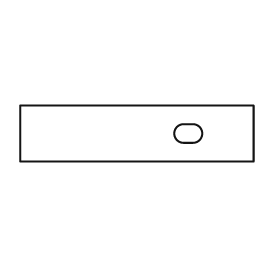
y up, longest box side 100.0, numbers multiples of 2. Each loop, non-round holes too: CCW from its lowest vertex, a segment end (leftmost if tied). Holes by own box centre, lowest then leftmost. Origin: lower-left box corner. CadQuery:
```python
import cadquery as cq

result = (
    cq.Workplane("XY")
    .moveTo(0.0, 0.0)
    .lineTo(100.0, 0.0)
    .lineTo(100.0, 24.0)
    .lineTo(0.0, 24.0)
    .close()
    .moveTo(70.0, 8.0)
    .lineTo(74.0, 8.0)
    .threePointArc((78.0, 12.0), (74.0, 16.0))
    .lineTo(70.0, 16.0)
    .threePointArc((66.0, 12.0), (70.0, 8.0))
    .close()
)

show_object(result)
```